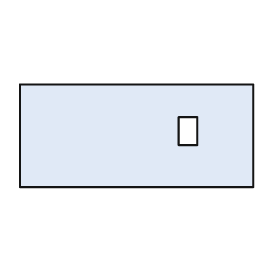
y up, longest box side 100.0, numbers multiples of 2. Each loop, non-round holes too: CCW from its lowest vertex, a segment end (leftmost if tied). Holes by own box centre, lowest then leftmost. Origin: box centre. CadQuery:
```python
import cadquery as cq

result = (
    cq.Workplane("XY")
    .moveTo(-50.0, -22.0)
    .lineTo(50.0, -22.0)
    .lineTo(50.0, 22.0)
    .lineTo(-50.0, 22.0)
    .close()
    .moveTo(18.0, -4.0)
    .lineTo(26.0, -4.0)
    .lineTo(26.0, 8.0)
    .lineTo(18.0, 8.0)
    .close()
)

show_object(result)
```